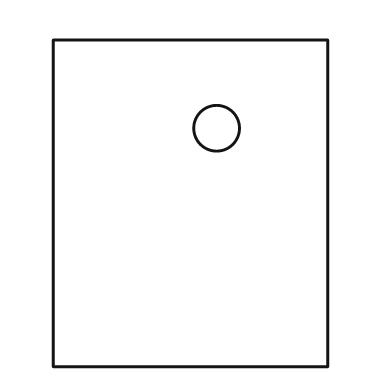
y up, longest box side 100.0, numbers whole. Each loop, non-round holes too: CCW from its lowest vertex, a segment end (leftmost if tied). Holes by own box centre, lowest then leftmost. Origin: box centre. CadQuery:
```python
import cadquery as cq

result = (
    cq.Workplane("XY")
    .moveTo(-42.0, -50.0)
    .lineTo(42.0, -50.0)
    .lineTo(42.0, 50.0)
    .lineTo(-42.0, 50.0)
    .close()
    .moveTo(8.0, 23.0)
    .circle(7.0)
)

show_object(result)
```